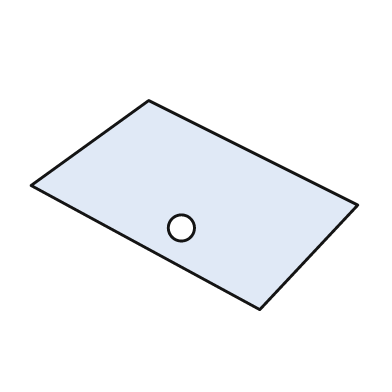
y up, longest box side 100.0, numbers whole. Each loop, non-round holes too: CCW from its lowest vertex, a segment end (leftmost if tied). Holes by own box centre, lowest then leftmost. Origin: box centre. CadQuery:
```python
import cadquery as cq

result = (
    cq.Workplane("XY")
    .moveTo(20.0, -32.0)
    .lineTo(50.0, 0.0)
    .lineTo(-14.0, 32.0)
    .lineTo(-50.0, 6.0)
    .close()
    .moveTo(-4.0, -7.0)
    .circle(4.0)
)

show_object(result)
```